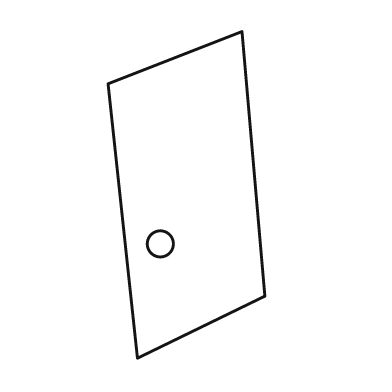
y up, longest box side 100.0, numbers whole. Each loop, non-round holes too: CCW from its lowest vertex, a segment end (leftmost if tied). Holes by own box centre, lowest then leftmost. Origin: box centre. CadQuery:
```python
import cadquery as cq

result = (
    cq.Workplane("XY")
    .moveTo(-15.0, -50.0)
    .lineTo(24.0, -31.0)
    .lineTo(17.0, 50.0)
    .lineTo(-24.0, 34.0)
    .close()
    .moveTo(-8.0, -15.0)
    .circle(4.0)
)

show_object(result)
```